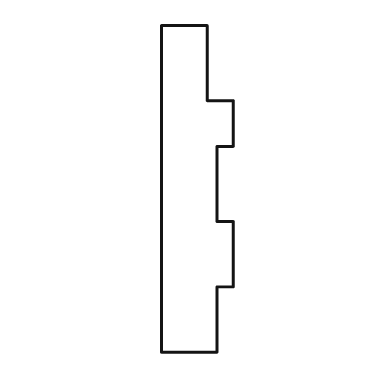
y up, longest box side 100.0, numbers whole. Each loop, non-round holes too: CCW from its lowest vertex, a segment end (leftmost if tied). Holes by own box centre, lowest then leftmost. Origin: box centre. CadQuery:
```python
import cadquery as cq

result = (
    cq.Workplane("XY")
    .moveTo(-11.0, -50.0)
    .lineTo(6.0, -50.0)
    .lineTo(6.0, -30.0)
    .lineTo(11.0, -30.0)
    .lineTo(11.0, -10.0)
    .lineTo(6.0, -10.0)
    .lineTo(6.0, 13.0)
    .lineTo(11.0, 13.0)
    .lineTo(11.0, 27.0)
    .lineTo(3.0, 27.0)
    .lineTo(3.0, 50.0)
    .lineTo(-11.0, 50.0)
    .close()
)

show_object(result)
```